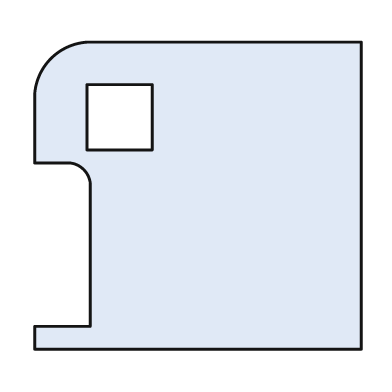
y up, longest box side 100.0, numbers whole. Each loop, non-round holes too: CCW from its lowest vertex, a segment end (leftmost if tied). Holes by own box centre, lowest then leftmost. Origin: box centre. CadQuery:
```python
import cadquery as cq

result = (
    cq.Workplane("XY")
    .moveTo(-50.0, -47.0)
    .lineTo(50.0, -47.0)
    .lineTo(50.0, 47.0)
    .lineTo(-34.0, 47.0)
    .threePointArc((-45.0, 42.0), (-50.0, 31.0))
    .lineTo(-50.0, 10.0)
    .lineTo(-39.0, 10.0)
    .threePointArc((-35.0, 8.0), (-33.0, 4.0))
    .lineTo(-33.0, -40.0)
    .lineTo(-50.0, -40.0)
    .close()
    .moveTo(-34.0, 14.0)
    .lineTo(-14.0, 14.0)
    .lineTo(-14.0, 34.0)
    .lineTo(-34.0, 34.0)
    .close()
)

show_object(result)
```